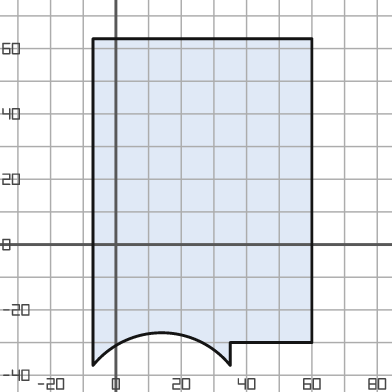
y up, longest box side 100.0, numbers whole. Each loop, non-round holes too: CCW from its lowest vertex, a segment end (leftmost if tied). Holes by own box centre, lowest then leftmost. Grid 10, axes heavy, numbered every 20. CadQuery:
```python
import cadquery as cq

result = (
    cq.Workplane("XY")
    .moveTo(-7.0, -37.0)
    .threePointArc((14.0, -27.0), (35.0, -37.0))
    .lineTo(35.0, -30.0)
    .lineTo(60.0, -30.0)
    .lineTo(60.0, 63.0)
    .lineTo(-7.0, 63.0)
    .close()
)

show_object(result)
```